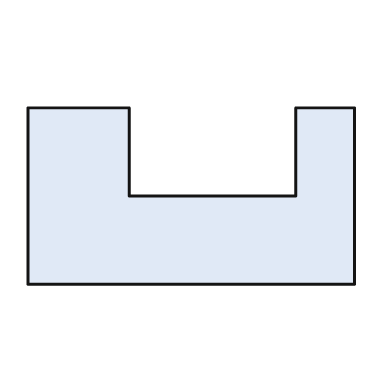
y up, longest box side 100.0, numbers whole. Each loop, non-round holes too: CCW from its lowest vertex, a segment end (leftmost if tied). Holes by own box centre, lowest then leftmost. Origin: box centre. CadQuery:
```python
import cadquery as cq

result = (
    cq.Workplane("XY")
    .moveTo(-50.0, -27.0)
    .lineTo(50.0, -27.0)
    .lineTo(50.0, 27.0)
    .lineTo(32.0, 27.0)
    .lineTo(32.0, 0.0)
    .lineTo(-19.0, 0.0)
    .lineTo(-19.0, 27.0)
    .lineTo(-50.0, 27.0)
    .close()
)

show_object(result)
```